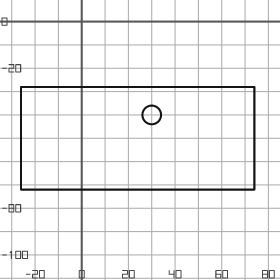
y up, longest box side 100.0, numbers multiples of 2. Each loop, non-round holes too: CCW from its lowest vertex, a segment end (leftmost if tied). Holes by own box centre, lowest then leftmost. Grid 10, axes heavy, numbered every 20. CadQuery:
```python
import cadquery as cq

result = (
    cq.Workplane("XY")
    .moveTo(-26.0, -72.0)
    .lineTo(74.0, -72.0)
    .lineTo(74.0, -28.0)
    .lineTo(-26.0, -28.0)
    .close()
    .moveTo(30.0, -40.0)
    .circle(4.0)
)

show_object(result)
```